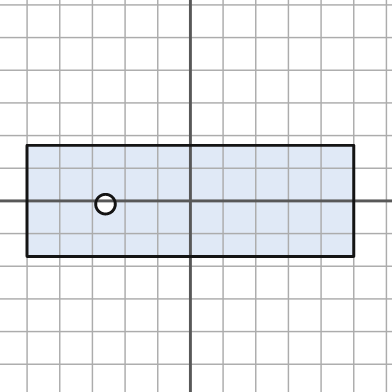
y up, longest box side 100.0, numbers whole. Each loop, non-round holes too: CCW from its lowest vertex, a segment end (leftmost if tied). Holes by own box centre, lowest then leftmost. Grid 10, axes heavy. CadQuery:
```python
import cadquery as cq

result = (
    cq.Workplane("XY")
    .moveTo(-50.0, -17.0)
    .lineTo(50.0, -17.0)
    .lineTo(50.0, 17.0)
    .lineTo(-50.0, 17.0)
    .close()
    .moveTo(-26.0, -1.0)
    .circle(3.0)
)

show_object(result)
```